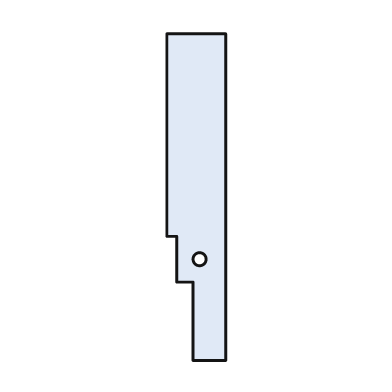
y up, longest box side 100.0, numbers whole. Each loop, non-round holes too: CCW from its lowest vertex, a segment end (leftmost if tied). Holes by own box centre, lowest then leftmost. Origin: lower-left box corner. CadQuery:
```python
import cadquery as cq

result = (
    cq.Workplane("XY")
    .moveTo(8.0, 0.0)
    .lineTo(18.0, 0.0)
    .lineTo(18.0, 100.0)
    .lineTo(0.0, 100.0)
    .lineTo(0.0, 38.0)
    .lineTo(3.0, 38.0)
    .lineTo(3.0, 24.0)
    .lineTo(8.0, 24.0)
    .close()
    .moveTo(10.0, 31.0)
    .circle(2.0)
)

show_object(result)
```